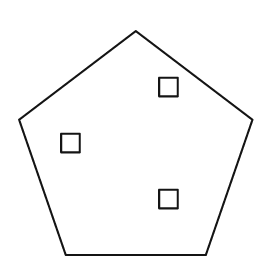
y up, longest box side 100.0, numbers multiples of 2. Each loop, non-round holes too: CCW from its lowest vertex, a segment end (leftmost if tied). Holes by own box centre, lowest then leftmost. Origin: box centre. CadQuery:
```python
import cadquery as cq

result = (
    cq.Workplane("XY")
    .moveTo(-30.0, -48.0)
    .lineTo(30.0, -48.0)
    .lineTo(50.0, 10.0)
    .lineTo(0.0, 48.0)
    .lineTo(-50.0, 10.0)
    .close()
    .moveTo(10.0, -28.0)
    .lineTo(18.0, -28.0)
    .lineTo(18.0, -20.0)
    .lineTo(10.0, -20.0)
    .close()
    .moveTo(-32.0, -4.0)
    .lineTo(-24.0, -4.0)
    .lineTo(-24.0, 4.0)
    .lineTo(-32.0, 4.0)
    .close()
    .moveTo(10.0, 20.0)
    .lineTo(18.0, 20.0)
    .lineTo(18.0, 28.0)
    .lineTo(10.0, 28.0)
    .close()
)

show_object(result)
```